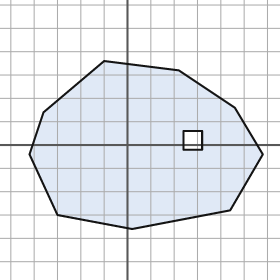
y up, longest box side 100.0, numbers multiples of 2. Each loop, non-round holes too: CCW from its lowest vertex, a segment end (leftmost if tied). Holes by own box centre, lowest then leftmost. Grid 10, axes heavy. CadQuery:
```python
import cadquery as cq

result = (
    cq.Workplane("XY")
    .moveTo(2.0, -36.0)
    .lineTo(44.0, -28.0)
    .lineTo(58.0, -4.0)
    .lineTo(46.0, 16.0)
    .lineTo(22.0, 32.0)
    .lineTo(-10.0, 36.0)
    .lineTo(-36.0, 14.0)
    .lineTo(-42.0, -4.0)
    .lineTo(-30.0, -30.0)
    .close()
    .moveTo(24.0, -2.0)
    .lineTo(32.0, -2.0)
    .lineTo(32.0, 6.0)
    .lineTo(24.0, 6.0)
    .close()
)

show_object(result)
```